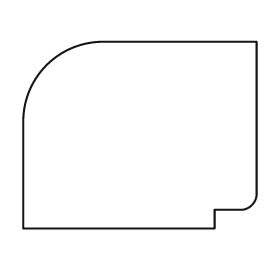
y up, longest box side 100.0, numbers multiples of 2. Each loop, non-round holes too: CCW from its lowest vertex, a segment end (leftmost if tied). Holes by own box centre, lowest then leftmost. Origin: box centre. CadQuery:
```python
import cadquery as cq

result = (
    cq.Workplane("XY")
    .moveTo(-50.0, -40.0)
    .lineTo(32.0, -40.0)
    .lineTo(32.0, -32.0)
    .lineTo(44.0, -32.0)
    .threePointArc((48.0, -30.0), (50.0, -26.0))
    .lineTo(50.0, 40.0)
    .lineTo(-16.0, 40.0)
    .threePointArc((-40.0, 30.0), (-50.0, 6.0))
    .close()
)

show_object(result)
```